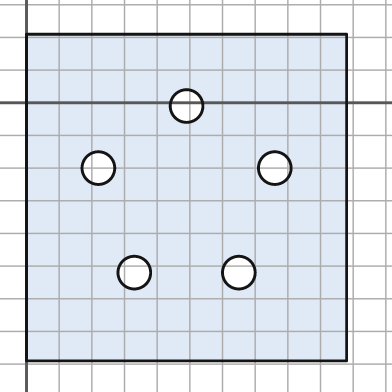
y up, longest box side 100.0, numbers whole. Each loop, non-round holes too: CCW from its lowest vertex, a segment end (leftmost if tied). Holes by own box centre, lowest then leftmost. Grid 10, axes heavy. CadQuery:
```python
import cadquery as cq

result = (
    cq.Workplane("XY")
    .moveTo(0.0, -79.0)
    .lineTo(98.0, -79.0)
    .lineTo(98.0, 21.0)
    .lineTo(0.0, 21.0)
    .close()
    .moveTo(33.0, -52.0)
    .circle(5.0)
    .moveTo(65.0, -52.0)
    .circle(5.0)
    .moveTo(22.0, -20.0)
    .circle(5.0)
    .moveTo(76.0, -20.0)
    .circle(5.0)
    .moveTo(49.0, -1.0)
    .circle(5.0)
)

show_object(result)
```